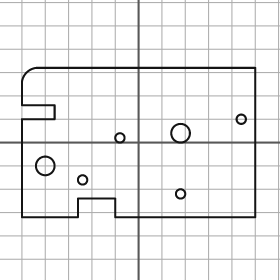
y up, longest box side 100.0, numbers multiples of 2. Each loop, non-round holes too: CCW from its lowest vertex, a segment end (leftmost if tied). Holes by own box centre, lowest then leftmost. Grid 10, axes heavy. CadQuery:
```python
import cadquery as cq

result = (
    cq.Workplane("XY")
    .moveTo(-50.0, -32.0)
    .lineTo(-26.0, -32.0)
    .lineTo(-26.0, -24.0)
    .lineTo(-10.0, -24.0)
    .lineTo(-10.0, -32.0)
    .lineTo(50.0, -32.0)
    .lineTo(50.0, 32.0)
    .lineTo(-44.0, 32.0)
    .threePointArc((-48.0, 30.0), (-50.0, 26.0))
    .lineTo(-50.0, 16.0)
    .lineTo(-36.0, 16.0)
    .lineTo(-36.0, 10.0)
    .lineTo(-50.0, 10.0)
    .close()
    .moveTo(18.0, -22.0)
    .circle(2.0)
    .moveTo(-24.0, -16.0)
    .circle(2.0)
    .moveTo(-40.0, -10.0)
    .circle(4.0)
    .moveTo(-8.0, 2.0)
    .circle(2.0)
    .moveTo(18.0, 4.0)
    .circle(4.0)
    .moveTo(44.0, 10.0)
    .circle(2.0)
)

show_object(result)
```